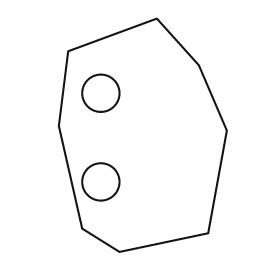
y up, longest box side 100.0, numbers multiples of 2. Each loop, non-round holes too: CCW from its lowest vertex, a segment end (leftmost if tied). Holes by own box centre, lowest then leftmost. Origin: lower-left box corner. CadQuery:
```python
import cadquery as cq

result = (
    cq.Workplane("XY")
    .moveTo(26.0, 0.0)
    .lineTo(64.0, 8.0)
    .lineTo(72.0, 52.0)
    .lineTo(60.0, 80.0)
    .lineTo(42.0, 100.0)
    .lineTo(4.0, 86.0)
    .lineTo(0.0, 54.0)
    .lineTo(10.0, 10.0)
    .close()
    .moveTo(18.0, 30.0)
    .circle(8.0)
    .moveTo(18.0, 68.0)
    .circle(8.0)
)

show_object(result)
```